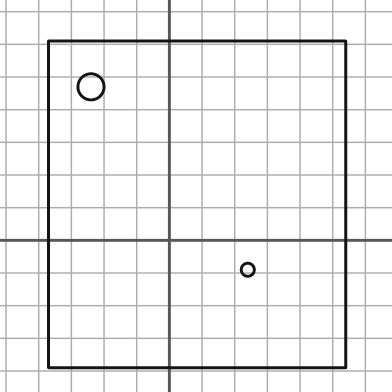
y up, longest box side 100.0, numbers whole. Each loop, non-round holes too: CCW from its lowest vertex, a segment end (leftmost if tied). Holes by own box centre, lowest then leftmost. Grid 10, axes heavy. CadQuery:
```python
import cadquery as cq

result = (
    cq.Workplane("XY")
    .moveTo(-37.0, -39.0)
    .lineTo(54.0, -39.0)
    .lineTo(54.0, 61.0)
    .lineTo(-37.0, 61.0)
    .close()
    .moveTo(24.0, -9.0)
    .circle(2.0)
    .moveTo(-24.0, 47.0)
    .circle(4.0)
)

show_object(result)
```